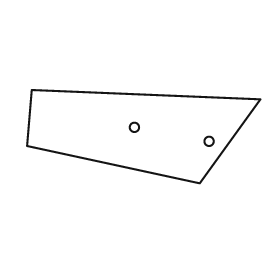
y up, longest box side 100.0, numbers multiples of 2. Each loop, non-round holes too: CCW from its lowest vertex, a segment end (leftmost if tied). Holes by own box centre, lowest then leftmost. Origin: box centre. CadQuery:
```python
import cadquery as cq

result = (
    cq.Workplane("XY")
    .moveTo(24.0, -20.0)
    .lineTo(50.0, 16.0)
    .lineTo(-48.0, 20.0)
    .lineTo(-50.0, -4.0)
    .close()
    .moveTo(28.0, -2.0)
    .circle(2.0)
    .moveTo(-4.0, 4.0)
    .circle(2.0)
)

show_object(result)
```